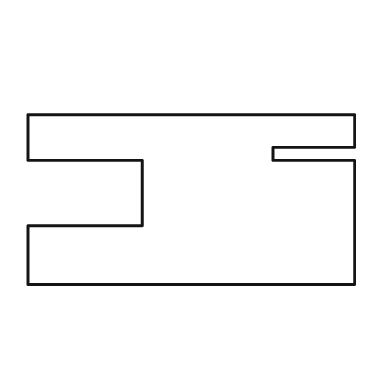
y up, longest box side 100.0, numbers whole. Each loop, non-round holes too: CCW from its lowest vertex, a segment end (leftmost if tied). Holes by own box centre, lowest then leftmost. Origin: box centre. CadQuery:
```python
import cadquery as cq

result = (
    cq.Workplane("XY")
    .moveTo(-50.0, -26.0)
    .lineTo(50.0, -26.0)
    .lineTo(50.0, 12.0)
    .lineTo(25.0, 12.0)
    .lineTo(25.0, 16.0)
    .lineTo(50.0, 16.0)
    .lineTo(50.0, 26.0)
    .lineTo(-50.0, 26.0)
    .lineTo(-50.0, 12.0)
    .lineTo(-15.0, 12.0)
    .lineTo(-15.0, -8.0)
    .lineTo(-50.0, -8.0)
    .close()
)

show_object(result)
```